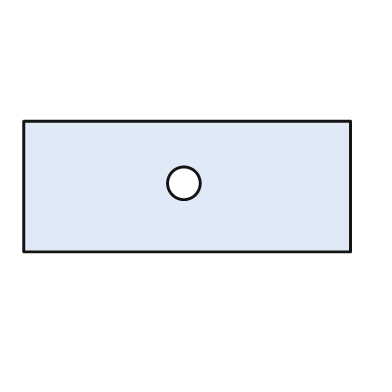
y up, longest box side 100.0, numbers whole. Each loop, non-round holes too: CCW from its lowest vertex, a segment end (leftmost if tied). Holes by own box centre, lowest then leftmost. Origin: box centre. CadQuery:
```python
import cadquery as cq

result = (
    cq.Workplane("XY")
    .moveTo(-50.0, -20.0)
    .lineTo(50.0, -20.0)
    .lineTo(50.0, 20.0)
    .lineTo(-50.0, 20.0)
    .close()
    .moveTo(-1.0, 1.0)
    .circle(5.0)
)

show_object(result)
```